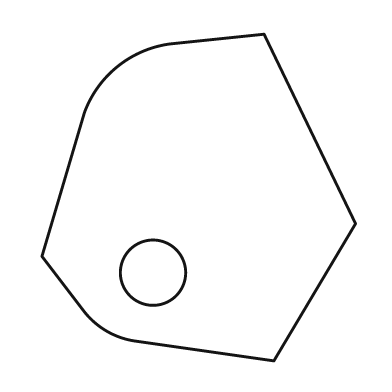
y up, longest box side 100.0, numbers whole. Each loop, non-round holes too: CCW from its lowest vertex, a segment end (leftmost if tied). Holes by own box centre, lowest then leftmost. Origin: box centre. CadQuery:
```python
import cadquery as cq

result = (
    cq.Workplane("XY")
    .moveTo(23.0, -50.0)
    .lineTo(48.0, -8.0)
    .lineTo(20.0, 50.0)
    .lineTo(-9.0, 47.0)
    .threePointArc((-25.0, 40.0), (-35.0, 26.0))
    .lineTo(-48.0, -18.0)
    .lineTo(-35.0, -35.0)
    .threePointArc((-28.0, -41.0), (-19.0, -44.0))
    .close()
    .moveTo(-14.0, -23.0)
    .circle(10.0)
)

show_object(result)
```